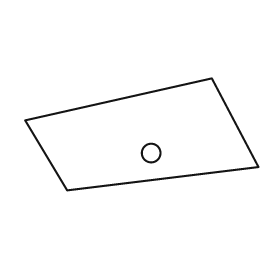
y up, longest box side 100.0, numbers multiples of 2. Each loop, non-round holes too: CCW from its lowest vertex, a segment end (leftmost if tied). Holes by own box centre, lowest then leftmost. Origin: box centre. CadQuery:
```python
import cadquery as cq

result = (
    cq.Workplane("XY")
    .moveTo(-32.0, -24.0)
    .lineTo(50.0, -14.0)
    .lineTo(30.0, 24.0)
    .lineTo(-50.0, 6.0)
    .close()
    .moveTo(4.0, -8.0)
    .circle(4.0)
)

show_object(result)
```